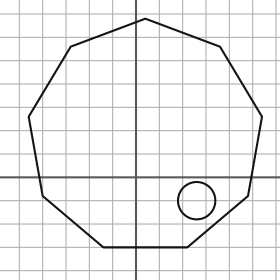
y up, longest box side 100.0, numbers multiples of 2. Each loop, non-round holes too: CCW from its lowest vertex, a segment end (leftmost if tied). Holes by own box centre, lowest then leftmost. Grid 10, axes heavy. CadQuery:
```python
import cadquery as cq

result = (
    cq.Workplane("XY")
    .moveTo(-14.0, -30.0)
    .lineTo(22.0, -30.0)
    .lineTo(48.0, -8.0)
    .lineTo(54.0, 26.0)
    .lineTo(36.0, 56.0)
    .lineTo(4.0, 68.0)
    .lineTo(-28.0, 56.0)
    .lineTo(-46.0, 26.0)
    .lineTo(-40.0, -8.0)
    .close()
    .moveTo(26.0, -10.0)
    .circle(8.0)
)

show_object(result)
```